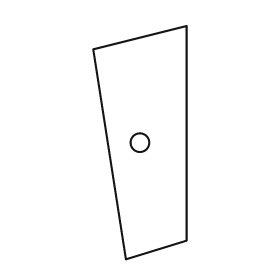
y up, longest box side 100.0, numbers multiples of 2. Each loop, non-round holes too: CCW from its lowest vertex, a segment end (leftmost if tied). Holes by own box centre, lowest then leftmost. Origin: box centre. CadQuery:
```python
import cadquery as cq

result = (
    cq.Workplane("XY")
    .moveTo(-6.0, -50.0)
    .lineTo(20.0, -42.0)
    .lineTo(20.0, 50.0)
    .lineTo(-20.0, 40.0)
    .close()
    .moveTo(0.0, 0.0)
    .circle(4.0)
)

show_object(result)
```